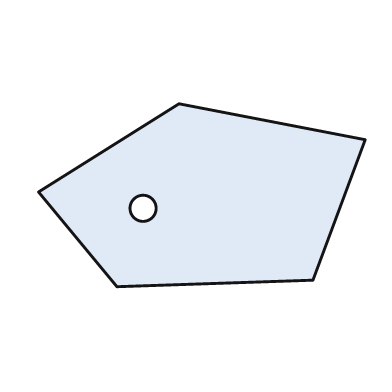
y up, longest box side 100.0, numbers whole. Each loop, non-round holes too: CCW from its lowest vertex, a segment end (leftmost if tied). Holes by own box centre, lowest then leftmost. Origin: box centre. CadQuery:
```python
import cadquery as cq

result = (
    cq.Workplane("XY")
    .moveTo(-26.0, -28.0)
    .lineTo(34.0, -26.0)
    .lineTo(50.0, 17.0)
    .lineTo(-7.0, 28.0)
    .lineTo(-50.0, 1.0)
    .close()
    .moveTo(-18.0, -4.0)
    .circle(4.0)
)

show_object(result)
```